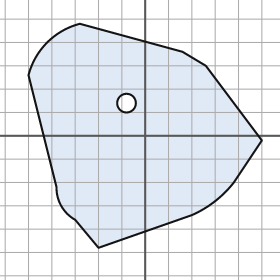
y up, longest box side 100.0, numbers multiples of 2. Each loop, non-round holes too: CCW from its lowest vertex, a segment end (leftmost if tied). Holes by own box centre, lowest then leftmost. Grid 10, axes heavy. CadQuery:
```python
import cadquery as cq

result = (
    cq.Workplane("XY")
    .moveTo(-20.0, -48.0)
    .lineTo(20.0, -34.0)
    .threePointArc((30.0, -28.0), (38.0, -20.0))
    .lineTo(50.0, -2.0)
    .lineTo(26.0, 30.0)
    .lineTo(16.0, 36.0)
    .lineTo(-28.0, 48.0)
    .threePointArc((-42.0, 40.0), (-50.0, 26.0))
    .lineTo(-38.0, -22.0)
    .threePointArc((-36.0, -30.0), (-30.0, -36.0))
    .close()
    .moveTo(-8.0, 14.0)
    .circle(4.0)
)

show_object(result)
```